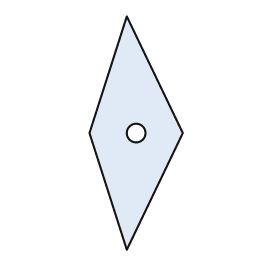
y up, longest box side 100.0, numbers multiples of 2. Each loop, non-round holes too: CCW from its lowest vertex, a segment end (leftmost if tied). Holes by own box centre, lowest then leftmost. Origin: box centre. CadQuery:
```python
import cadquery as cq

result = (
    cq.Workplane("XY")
    .moveTo(-4.0, -50.0)
    .lineTo(20.0, 0.0)
    .lineTo(-4.0, 50.0)
    .lineTo(-20.0, 0.0)
    .close()
    .moveTo(0.0, 0.0)
    .circle(4.0)
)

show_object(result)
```